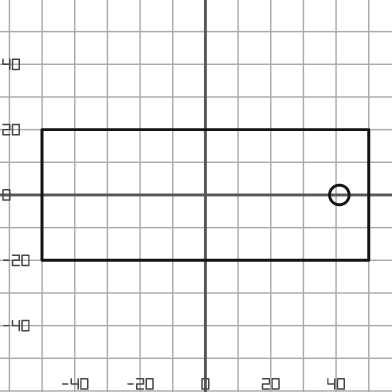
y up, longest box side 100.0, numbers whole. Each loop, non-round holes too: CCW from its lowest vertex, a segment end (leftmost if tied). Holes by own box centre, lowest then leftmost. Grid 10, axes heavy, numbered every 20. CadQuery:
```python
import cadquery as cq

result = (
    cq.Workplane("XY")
    .moveTo(-50.0, -20.0)
    .lineTo(50.0, -20.0)
    .lineTo(50.0, 20.0)
    .lineTo(-50.0, 20.0)
    .close()
    .moveTo(41.0, 0.0)
    .circle(3.0)
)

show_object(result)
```